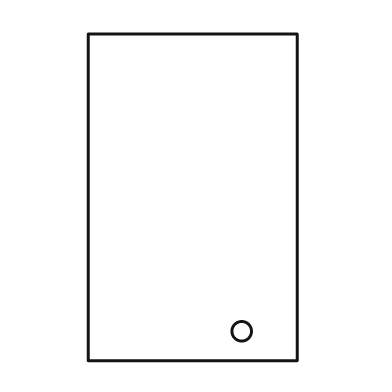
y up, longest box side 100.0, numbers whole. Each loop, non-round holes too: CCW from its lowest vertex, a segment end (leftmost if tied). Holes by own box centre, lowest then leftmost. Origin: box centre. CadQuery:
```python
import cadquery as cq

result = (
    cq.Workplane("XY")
    .moveTo(-32.0, -50.0)
    .lineTo(32.0, -50.0)
    .lineTo(32.0, 50.0)
    .lineTo(-32.0, 50.0)
    .close()
    .moveTo(15.0, -41.0)
    .circle(3.0)
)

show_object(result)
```